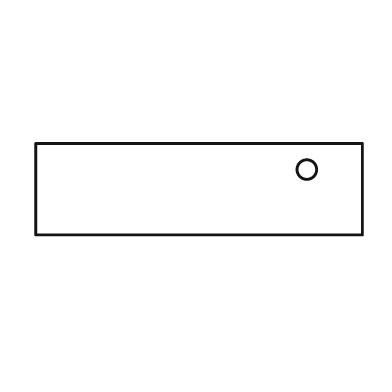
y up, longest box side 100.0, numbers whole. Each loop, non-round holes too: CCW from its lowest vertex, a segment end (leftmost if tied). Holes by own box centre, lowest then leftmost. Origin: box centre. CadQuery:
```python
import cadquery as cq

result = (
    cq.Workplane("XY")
    .moveTo(-50.0, -14.0)
    .lineTo(50.0, -14.0)
    .lineTo(50.0, 14.0)
    .lineTo(-50.0, 14.0)
    .close()
    .moveTo(33.0, 6.0)
    .circle(3.0)
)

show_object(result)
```